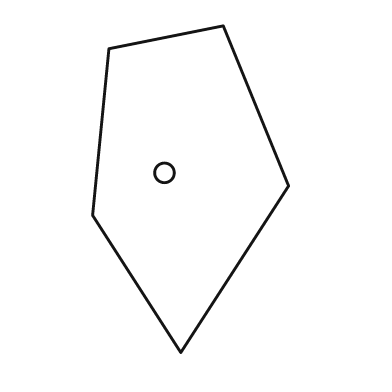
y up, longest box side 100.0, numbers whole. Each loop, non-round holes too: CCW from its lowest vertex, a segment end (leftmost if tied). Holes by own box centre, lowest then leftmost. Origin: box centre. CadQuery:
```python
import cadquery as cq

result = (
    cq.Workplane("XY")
    .moveTo(-3.0, -50.0)
    .lineTo(30.0, 1.0)
    .lineTo(10.0, 50.0)
    .lineTo(-25.0, 43.0)
    .lineTo(-30.0, -8.0)
    .close()
    .moveTo(-8.0, 5.0)
    .circle(3.0)
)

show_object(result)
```